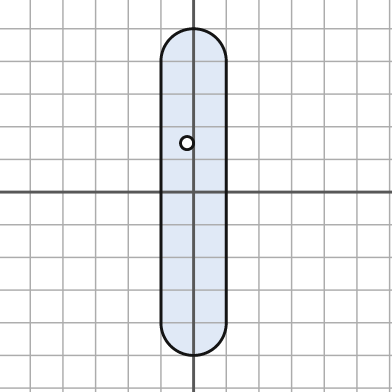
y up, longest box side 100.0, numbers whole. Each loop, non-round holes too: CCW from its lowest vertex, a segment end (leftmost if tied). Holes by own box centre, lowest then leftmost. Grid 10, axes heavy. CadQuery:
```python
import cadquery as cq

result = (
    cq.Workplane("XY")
    .moveTo(-10.0, -40.0)
    .threePointArc((0.0, -50.0), (10.0, -40.0))
    .lineTo(10.0, 40.0)
    .threePointArc((0.0, 50.0), (-10.0, 40.0))
    .close()
    .moveTo(-2.0, 15.0)
    .circle(2.0)
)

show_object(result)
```